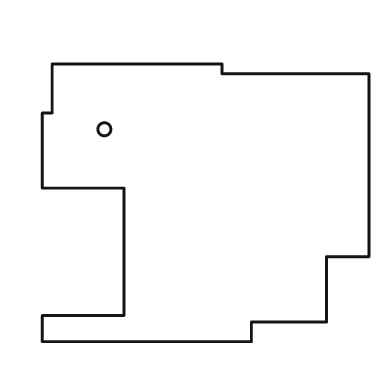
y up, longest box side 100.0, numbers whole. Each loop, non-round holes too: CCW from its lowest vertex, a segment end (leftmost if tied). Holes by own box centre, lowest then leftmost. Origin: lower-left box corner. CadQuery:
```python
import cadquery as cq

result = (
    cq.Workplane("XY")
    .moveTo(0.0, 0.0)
    .lineTo(64.0, 0.0)
    .lineTo(64.0, 6.0)
    .lineTo(87.0, 6.0)
    .lineTo(87.0, 26.0)
    .lineTo(100.0, 26.0)
    .lineTo(100.0, 82.0)
    .lineTo(55.0, 82.0)
    .lineTo(55.0, 85.0)
    .lineTo(3.0, 85.0)
    .lineTo(3.0, 70.0)
    .lineTo(0.0, 70.0)
    .lineTo(0.0, 47.0)
    .lineTo(25.0, 47.0)
    .lineTo(25.0, 8.0)
    .lineTo(0.0, 8.0)
    .close()
    .moveTo(19.0, 65.0)
    .circle(2.0)
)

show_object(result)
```